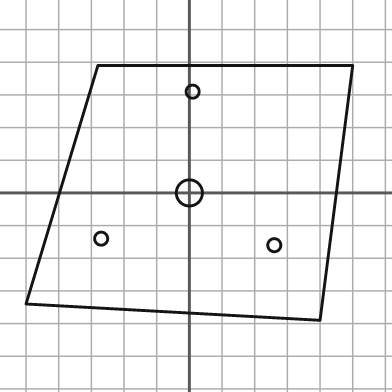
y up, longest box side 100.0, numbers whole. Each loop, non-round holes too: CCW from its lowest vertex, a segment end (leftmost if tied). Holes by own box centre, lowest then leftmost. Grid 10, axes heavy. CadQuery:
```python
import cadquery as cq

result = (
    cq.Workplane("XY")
    .moveTo(40.0, -39.0)
    .lineTo(50.0, 39.0)
    .lineTo(-28.0, 39.0)
    .lineTo(-50.0, -34.0)
    .close()
    .moveTo(26.0, -16.0)
    .circle(2.0)
    .moveTo(-27.0, -14.0)
    .circle(2.0)
    .moveTo(0.0, 0.0)
    .circle(4.0)
    .moveTo(1.0, 31.0)
    .circle(2.0)
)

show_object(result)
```